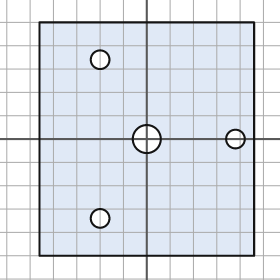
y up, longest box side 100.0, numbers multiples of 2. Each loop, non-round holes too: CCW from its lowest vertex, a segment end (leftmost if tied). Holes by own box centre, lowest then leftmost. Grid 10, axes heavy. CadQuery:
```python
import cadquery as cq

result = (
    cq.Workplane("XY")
    .moveTo(-46.0, -50.0)
    .lineTo(46.0, -50.0)
    .lineTo(46.0, 50.0)
    .lineTo(-46.0, 50.0)
    .close()
    .moveTo(-20.0, -34.0)
    .circle(4.0)
    .moveTo(0.0, 0.0)
    .circle(6.0)
    .moveTo(38.0, 0.0)
    .circle(4.0)
    .moveTo(-20.0, 34.0)
    .circle(4.0)
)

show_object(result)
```